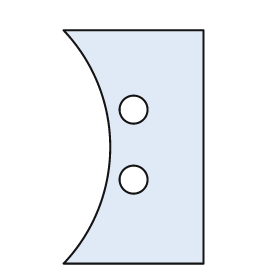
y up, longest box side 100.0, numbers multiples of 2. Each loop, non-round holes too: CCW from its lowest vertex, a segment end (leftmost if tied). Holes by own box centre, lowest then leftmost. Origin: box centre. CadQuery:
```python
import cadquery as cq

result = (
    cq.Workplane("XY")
    .moveTo(-30.0, -50.0)
    .lineTo(30.0, -50.0)
    .lineTo(30.0, 50.0)
    .lineTo(-30.0, 50.0)
    .threePointArc((-10.0, 0.0), (-30.0, -50.0))
    .close()
    .moveTo(0.0, -14.0)
    .circle(6.0)
    .moveTo(0.0, 16.0)
    .circle(6.0)
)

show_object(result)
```